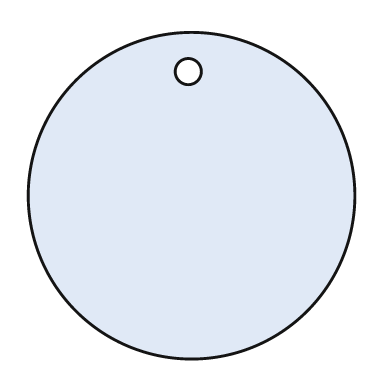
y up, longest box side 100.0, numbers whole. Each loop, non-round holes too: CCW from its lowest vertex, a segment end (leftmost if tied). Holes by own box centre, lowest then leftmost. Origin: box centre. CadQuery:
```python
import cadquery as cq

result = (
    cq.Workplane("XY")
    .moveTo(0.0, 0.0)
    .circle(50.0)
    .moveTo(-1.0, 38.0)
    .circle(4.0)
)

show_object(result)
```